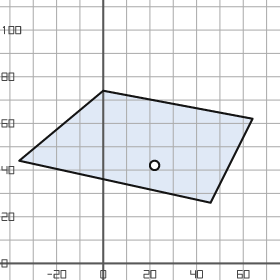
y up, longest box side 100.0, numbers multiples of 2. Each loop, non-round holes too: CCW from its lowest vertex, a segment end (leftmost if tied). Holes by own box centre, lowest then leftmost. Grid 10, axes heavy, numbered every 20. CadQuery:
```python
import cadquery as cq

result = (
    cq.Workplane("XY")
    .moveTo(46.0, 26.0)
    .lineTo(64.0, 62.0)
    .lineTo(0.0, 74.0)
    .lineTo(-36.0, 44.0)
    .close()
    .moveTo(22.0, 42.0)
    .circle(2.0)
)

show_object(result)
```